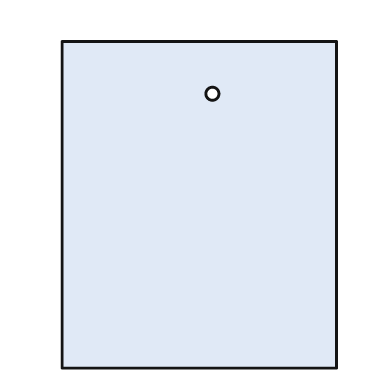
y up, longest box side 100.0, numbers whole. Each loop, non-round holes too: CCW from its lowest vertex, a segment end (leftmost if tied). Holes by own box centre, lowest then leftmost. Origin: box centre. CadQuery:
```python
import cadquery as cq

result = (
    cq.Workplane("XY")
    .moveTo(-42.0, -50.0)
    .lineTo(42.0, -50.0)
    .lineTo(42.0, 50.0)
    .lineTo(-42.0, 50.0)
    .close()
    .moveTo(4.0, 34.0)
    .circle(2.0)
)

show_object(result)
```